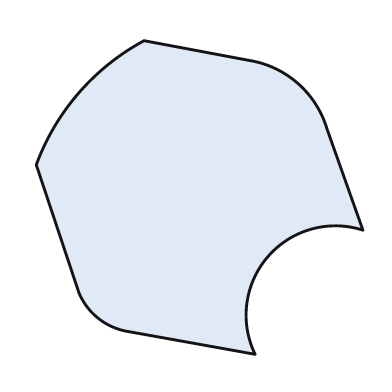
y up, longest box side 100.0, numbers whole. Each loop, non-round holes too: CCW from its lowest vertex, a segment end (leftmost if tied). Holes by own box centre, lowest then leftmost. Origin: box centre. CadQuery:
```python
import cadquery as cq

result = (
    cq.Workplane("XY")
    .moveTo(17.0, -48.0)
    .threePointArc((21.0, -18.0), (50.0, -10.0))
    .lineTo(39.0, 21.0)
    .threePointArc((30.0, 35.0), (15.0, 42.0))
    .lineTo(-17.0, 48.0)
    .threePointArc((-37.0, 32.0), (-50.0, 10.0))
    .lineTo(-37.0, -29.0)
    .threePointArc((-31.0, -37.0), (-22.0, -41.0))
    .close()
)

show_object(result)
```